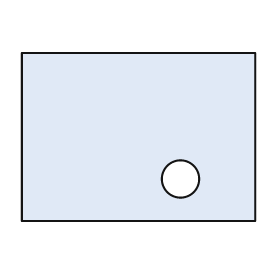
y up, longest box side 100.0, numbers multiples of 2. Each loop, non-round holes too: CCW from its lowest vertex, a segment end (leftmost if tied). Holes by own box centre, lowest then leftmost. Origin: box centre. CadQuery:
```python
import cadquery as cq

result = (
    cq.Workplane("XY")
    .moveTo(-50.0, -36.0)
    .lineTo(50.0, -36.0)
    .lineTo(50.0, 36.0)
    .lineTo(-50.0, 36.0)
    .close()
    .moveTo(18.0, -18.0)
    .circle(8.0)
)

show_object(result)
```